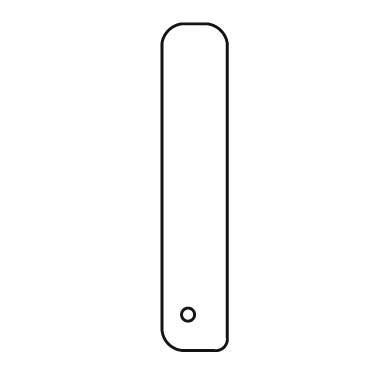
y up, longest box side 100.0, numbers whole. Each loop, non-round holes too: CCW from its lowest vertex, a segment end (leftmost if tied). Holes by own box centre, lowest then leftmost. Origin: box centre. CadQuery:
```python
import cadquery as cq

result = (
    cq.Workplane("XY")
    .moveTo(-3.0, -50.0)
    .lineTo(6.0, -50.0)
    .threePointArc((9.0, -49.0), (10.0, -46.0))
    .lineTo(10.0, 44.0)
    .threePointArc((8.0, 48.0), (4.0, 50.0))
    .lineTo(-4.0, 50.0)
    .threePointArc((-8.0, 48.0), (-10.0, 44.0))
    .lineTo(-10.0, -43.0)
    .threePointArc((-8.0, -48.0), (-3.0, -50.0))
    .close()
    .moveTo(-2.0, -39.0)
    .circle(2.0)
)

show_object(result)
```